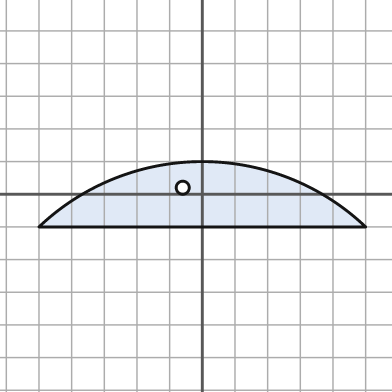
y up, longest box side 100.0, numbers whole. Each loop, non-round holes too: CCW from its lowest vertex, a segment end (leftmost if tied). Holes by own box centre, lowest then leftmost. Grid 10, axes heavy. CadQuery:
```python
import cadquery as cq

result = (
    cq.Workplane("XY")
    .moveTo(-50.0, -10.0)
    .lineTo(50.0, -10.0)
    .threePointArc((0.0, 10.0), (-50.0, -10.0))
    .close()
    .moveTo(-6.0, 2.0)
    .circle(2.0)
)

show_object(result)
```